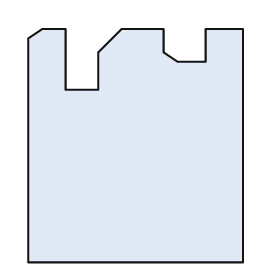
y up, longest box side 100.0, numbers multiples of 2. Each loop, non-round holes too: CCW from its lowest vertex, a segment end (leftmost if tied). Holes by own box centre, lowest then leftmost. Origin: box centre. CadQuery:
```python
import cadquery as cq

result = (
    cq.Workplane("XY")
    .moveTo(-46.0, -50.0)
    .lineTo(46.0, -50.0)
    .lineTo(46.0, 50.0)
    .lineTo(30.0, 50.0)
    .lineTo(30.0, 36.0)
    .lineTo(18.0, 36.0)
    .lineTo(12.0, 40.0)
    .lineTo(12.0, 50.0)
    .lineTo(-6.0, 50.0)
    .lineTo(-16.0, 40.0)
    .lineTo(-16.0, 24.0)
    .lineTo(-30.0, 24.0)
    .lineTo(-30.0, 50.0)
    .lineTo(-40.0, 50.0)
    .lineTo(-46.0, 46.0)
    .close()
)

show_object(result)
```